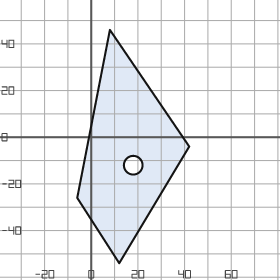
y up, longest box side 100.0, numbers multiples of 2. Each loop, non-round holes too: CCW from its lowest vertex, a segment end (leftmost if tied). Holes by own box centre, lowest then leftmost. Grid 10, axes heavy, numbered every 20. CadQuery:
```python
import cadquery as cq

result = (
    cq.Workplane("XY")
    .moveTo(12.0, -54.0)
    .lineTo(42.0, -4.0)
    .lineTo(8.0, 46.0)
    .lineTo(-6.0, -26.0)
    .close()
    .moveTo(18.0, -12.0)
    .circle(4.0)
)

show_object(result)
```